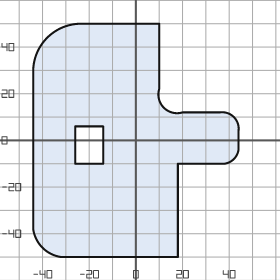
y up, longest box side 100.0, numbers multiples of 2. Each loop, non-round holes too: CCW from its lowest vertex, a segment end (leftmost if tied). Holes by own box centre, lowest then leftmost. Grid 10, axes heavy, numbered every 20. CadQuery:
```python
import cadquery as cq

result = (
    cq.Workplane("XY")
    .moveTo(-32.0, -50.0)
    .lineTo(18.0, -50.0)
    .lineTo(18.0, -10.0)
    .lineTo(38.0, -10.0)
    .threePointArc((42.0, -8.0), (44.0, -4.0))
    .lineTo(44.0, 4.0)
    .threePointArc((42.0, 10.0), (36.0, 12.0))
    .lineTo(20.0, 12.0)
    .threePointArc((12.0, 14.0), (10.0, 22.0))
    .lineTo(10.0, 50.0)
    .lineTo(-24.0, 50.0)
    .threePointArc((-38.0, 44.0), (-44.0, 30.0))
    .lineTo(-44.0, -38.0)
    .threePointArc((-40.0, -46.0), (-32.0, -50.0))
    .close()
    .moveTo(-26.0, -10.0)
    .lineTo(-14.0, -10.0)
    .lineTo(-14.0, 6.0)
    .lineTo(-26.0, 6.0)
    .close()
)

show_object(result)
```